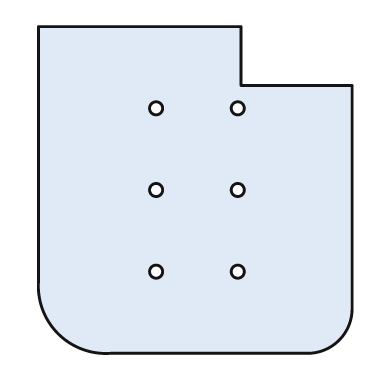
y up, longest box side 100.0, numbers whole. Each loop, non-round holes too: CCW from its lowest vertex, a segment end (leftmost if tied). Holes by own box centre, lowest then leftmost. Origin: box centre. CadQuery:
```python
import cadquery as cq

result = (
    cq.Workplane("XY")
    .moveTo(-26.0, -50.0)
    .lineTo(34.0, -50.0)
    .threePointArc((44.0, -46.0), (48.0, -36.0))
    .lineTo(48.0, 32.0)
    .lineTo(14.0, 32.0)
    .lineTo(14.0, 50.0)
    .lineTo(-48.0, 50.0)
    .lineTo(-48.0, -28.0)
    .threePointArc((-42.0, -44.0), (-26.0, -50.0))
    .close()
    .moveTo(-12.0, -25.0)
    .circle(2.0)
    .moveTo(13.0, -25.0)
    .circle(2.0)
    .moveTo(-12.0, 0.0)
    .circle(2.0)
    .moveTo(13.0, 0.0)
    .circle(2.0)
    .moveTo(-12.0, 25.0)
    .circle(2.0)
    .moveTo(13.0, 25.0)
    .circle(2.0)
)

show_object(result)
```